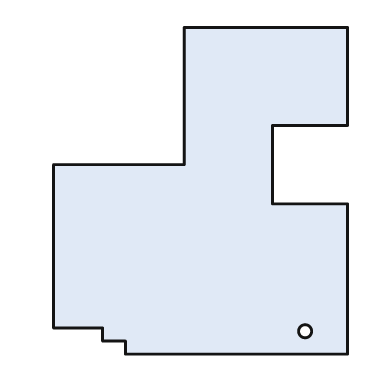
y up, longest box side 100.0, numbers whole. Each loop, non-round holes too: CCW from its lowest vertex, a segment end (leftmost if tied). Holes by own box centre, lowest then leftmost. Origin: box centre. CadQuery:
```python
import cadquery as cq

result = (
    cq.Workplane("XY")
    .moveTo(-23.0, -50.0)
    .lineTo(45.0, -50.0)
    .lineTo(45.0, -4.0)
    .lineTo(22.0, -4.0)
    .lineTo(22.0, 20.0)
    .lineTo(45.0, 20.0)
    .lineTo(45.0, 50.0)
    .lineTo(-5.0, 50.0)
    .lineTo(-5.0, 8.0)
    .lineTo(-45.0, 8.0)
    .lineTo(-45.0, -42.0)
    .lineTo(-30.0, -42.0)
    .lineTo(-30.0, -46.0)
    .lineTo(-23.0, -46.0)
    .close()
    .moveTo(32.0, -43.0)
    .circle(2.0)
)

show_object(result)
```